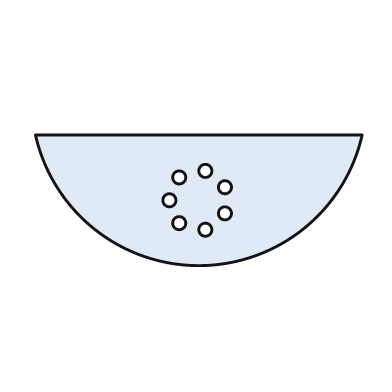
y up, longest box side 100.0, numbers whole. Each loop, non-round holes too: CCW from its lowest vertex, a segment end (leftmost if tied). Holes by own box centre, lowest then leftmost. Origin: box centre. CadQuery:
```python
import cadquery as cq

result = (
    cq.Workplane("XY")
    .moveTo(-50.0, 20.0)
    .threePointArc((0.0, -20.0), (50.0, 20.0))
    .close()
    .moveTo(2.0, -9.0)
    .circle(2.0)
    .moveTo(-6.0, -7.0)
    .circle(2.0)
    .moveTo(8.0, -4.0)
    .circle(2.0)
    .moveTo(-9.0, 0.0)
    .circle(2.0)
    .moveTo(8.0, 4.0)
    .circle(2.0)
    .moveTo(-6.0, 7.0)
    .circle(2.0)
    .moveTo(2.0, 9.0)
    .circle(2.0)
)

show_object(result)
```